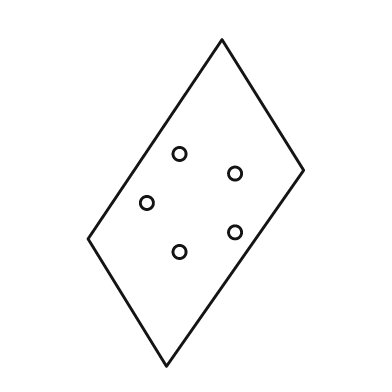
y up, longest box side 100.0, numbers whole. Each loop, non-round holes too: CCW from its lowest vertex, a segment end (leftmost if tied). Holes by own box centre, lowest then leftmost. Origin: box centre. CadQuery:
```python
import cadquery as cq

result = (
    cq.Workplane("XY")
    .moveTo(-9.0, -50.0)
    .lineTo(33.0, 10.0)
    .lineTo(8.0, 50.0)
    .lineTo(-33.0, -11.0)
    .close()
    .moveTo(-5.0, -15.0)
    .circle(2.0)
    .moveTo(12.0, -9.0)
    .circle(2.0)
    .moveTo(-15.0, 0.0)
    .circle(2.0)
    .moveTo(12.0, 9.0)
    .circle(2.0)
    .moveTo(-5.0, 15.0)
    .circle(2.0)
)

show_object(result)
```